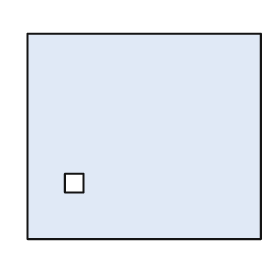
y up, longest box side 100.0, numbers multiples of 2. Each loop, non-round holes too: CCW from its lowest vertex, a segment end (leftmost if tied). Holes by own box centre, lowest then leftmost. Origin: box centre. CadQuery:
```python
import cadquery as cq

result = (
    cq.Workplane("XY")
    .moveTo(-50.0, -44.0)
    .lineTo(50.0, -44.0)
    .lineTo(50.0, 44.0)
    .lineTo(-50.0, 44.0)
    .close()
    .moveTo(-34.0, -24.0)
    .lineTo(-26.0, -24.0)
    .lineTo(-26.0, -16.0)
    .lineTo(-34.0, -16.0)
    .close()
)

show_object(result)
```